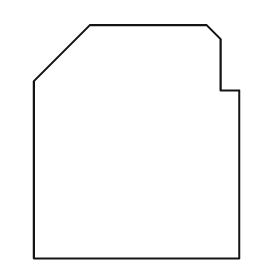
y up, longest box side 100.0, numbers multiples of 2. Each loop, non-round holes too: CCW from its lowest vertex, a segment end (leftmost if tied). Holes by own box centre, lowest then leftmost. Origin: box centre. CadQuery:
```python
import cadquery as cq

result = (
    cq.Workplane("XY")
    .moveTo(-44.0, -50.0)
    .lineTo(44.0, -50.0)
    .lineTo(44.0, 22.0)
    .lineTo(36.0, 22.0)
    .lineTo(36.0, 44.0)
    .lineTo(30.0, 50.0)
    .lineTo(-20.0, 50.0)
    .lineTo(-44.0, 26.0)
    .close()
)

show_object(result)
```